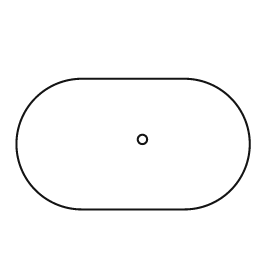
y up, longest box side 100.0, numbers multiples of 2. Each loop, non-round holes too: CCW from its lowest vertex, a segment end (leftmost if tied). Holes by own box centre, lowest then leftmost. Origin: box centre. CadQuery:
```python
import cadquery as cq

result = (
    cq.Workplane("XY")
    .moveTo(-22.0, -28.0)
    .lineTo(22.0, -28.0)
    .threePointArc((50.0, 0.0), (22.0, 28.0))
    .lineTo(-22.0, 28.0)
    .threePointArc((-50.0, 0.0), (-22.0, -28.0))
    .close()
    .moveTo(4.0, 2.0)
    .circle(2.0)
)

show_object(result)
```